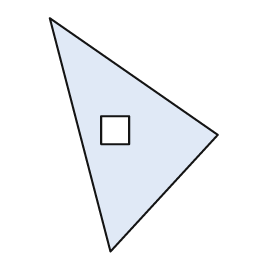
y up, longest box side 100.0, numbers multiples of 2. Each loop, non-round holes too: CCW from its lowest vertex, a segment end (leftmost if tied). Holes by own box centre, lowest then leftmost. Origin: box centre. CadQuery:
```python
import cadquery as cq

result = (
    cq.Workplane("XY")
    .moveTo(-10.0, -50.0)
    .lineTo(36.0, 0.0)
    .lineTo(-36.0, 50.0)
    .close()
    .moveTo(-14.0, -4.0)
    .lineTo(-2.0, -4.0)
    .lineTo(-2.0, 8.0)
    .lineTo(-14.0, 8.0)
    .close()
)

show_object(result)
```